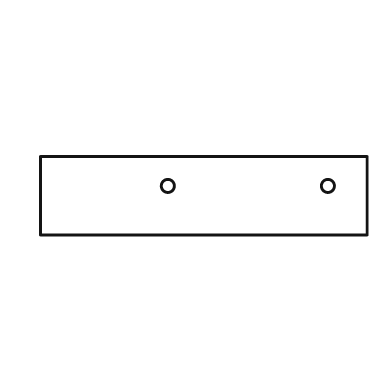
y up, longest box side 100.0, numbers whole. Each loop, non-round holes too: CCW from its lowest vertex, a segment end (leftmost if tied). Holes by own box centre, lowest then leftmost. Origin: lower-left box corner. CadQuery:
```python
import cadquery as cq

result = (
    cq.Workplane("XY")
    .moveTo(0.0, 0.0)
    .lineTo(100.0, 0.0)
    .lineTo(100.0, 24.0)
    .lineTo(0.0, 24.0)
    .close()
    .moveTo(39.0, 15.0)
    .circle(2.0)
    .moveTo(88.0, 15.0)
    .circle(2.0)
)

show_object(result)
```